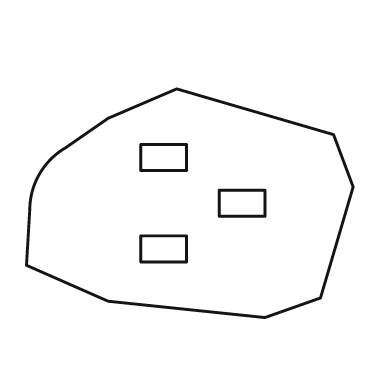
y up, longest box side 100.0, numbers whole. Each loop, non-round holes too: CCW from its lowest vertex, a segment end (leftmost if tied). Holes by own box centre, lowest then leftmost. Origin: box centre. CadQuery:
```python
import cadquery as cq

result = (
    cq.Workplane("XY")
    .moveTo(23.0, -35.0)
    .lineTo(40.0, -29.0)
    .lineTo(50.0, 5.0)
    .lineTo(44.0, 21.0)
    .lineTo(-4.0, 35.0)
    .lineTo(-25.0, 26.0)
    .lineTo(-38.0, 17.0)
    .threePointArc((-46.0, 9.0), (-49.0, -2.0))
    .lineTo(-50.0, -19.0)
    .lineTo(-25.0, -30.0)
    .close()
    .moveTo(-15.0, -18.0)
    .lineTo(-1.0, -18.0)
    .lineTo(-1.0, -10.0)
    .lineTo(-15.0, -10.0)
    .close()
    .moveTo(9.0, -4.0)
    .lineTo(23.0, -4.0)
    .lineTo(23.0, 4.0)
    .lineTo(9.0, 4.0)
    .close()
    .moveTo(-15.0, 10.0)
    .lineTo(-1.0, 10.0)
    .lineTo(-1.0, 18.0)
    .lineTo(-15.0, 18.0)
    .close()
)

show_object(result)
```